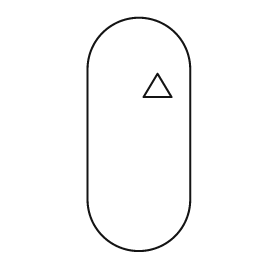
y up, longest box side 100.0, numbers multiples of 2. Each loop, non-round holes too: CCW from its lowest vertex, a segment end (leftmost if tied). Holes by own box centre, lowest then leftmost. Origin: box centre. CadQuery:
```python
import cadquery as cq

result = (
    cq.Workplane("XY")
    .moveTo(-22.0, -28.0)
    .threePointArc((0.0, -50.0), (22.0, -28.0))
    .lineTo(22.0, 28.0)
    .threePointArc((0.0, 50.0), (-22.0, 28.0))
    .close()
    .moveTo(2.0, 16.0)
    .lineTo(14.0, 16.0)
    .lineTo(8.0, 26.0)
    .close()
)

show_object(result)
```